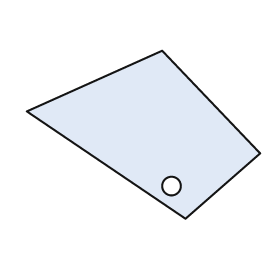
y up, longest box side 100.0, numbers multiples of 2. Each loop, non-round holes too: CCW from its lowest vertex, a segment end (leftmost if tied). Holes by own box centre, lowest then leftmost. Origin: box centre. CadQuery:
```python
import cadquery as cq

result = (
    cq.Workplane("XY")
    .moveTo(18.0, -36.0)
    .lineTo(50.0, -8.0)
    .lineTo(8.0, 36.0)
    .lineTo(-50.0, 10.0)
    .close()
    .moveTo(12.0, -22.0)
    .circle(4.0)
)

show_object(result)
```